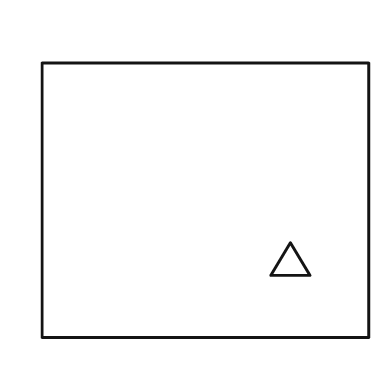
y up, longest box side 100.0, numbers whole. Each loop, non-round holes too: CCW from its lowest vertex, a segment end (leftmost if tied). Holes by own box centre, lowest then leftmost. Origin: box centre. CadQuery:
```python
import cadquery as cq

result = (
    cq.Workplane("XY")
    .moveTo(-50.0, -42.0)
    .lineTo(50.0, -42.0)
    .lineTo(50.0, 42.0)
    .lineTo(-50.0, 42.0)
    .close()
    .moveTo(20.0, -23.0)
    .lineTo(32.0, -23.0)
    .lineTo(26.0, -13.0)
    .close()
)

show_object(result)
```